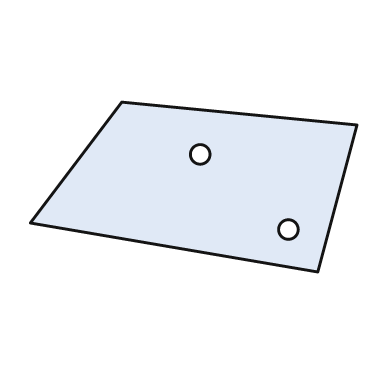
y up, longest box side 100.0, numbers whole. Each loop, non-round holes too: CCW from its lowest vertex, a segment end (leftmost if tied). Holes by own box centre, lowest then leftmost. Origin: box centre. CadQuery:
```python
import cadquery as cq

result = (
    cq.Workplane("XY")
    .moveTo(38.0, -26.0)
    .lineTo(50.0, 19.0)
    .lineTo(-22.0, 26.0)
    .lineTo(-50.0, -11.0)
    .close()
    .moveTo(29.0, -13.0)
    .circle(3.0)
    .moveTo(2.0, 10.0)
    .circle(3.0)
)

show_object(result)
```